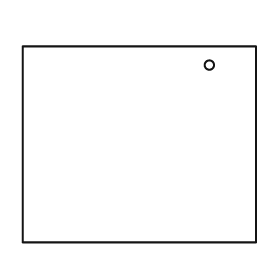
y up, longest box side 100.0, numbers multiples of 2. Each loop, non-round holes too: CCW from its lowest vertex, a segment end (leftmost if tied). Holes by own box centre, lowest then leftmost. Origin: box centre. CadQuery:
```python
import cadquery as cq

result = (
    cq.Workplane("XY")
    .moveTo(-50.0, -42.0)
    .lineTo(50.0, -42.0)
    .lineTo(50.0, 42.0)
    .lineTo(-50.0, 42.0)
    .close()
    .moveTo(30.0, 34.0)
    .circle(2.0)
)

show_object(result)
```